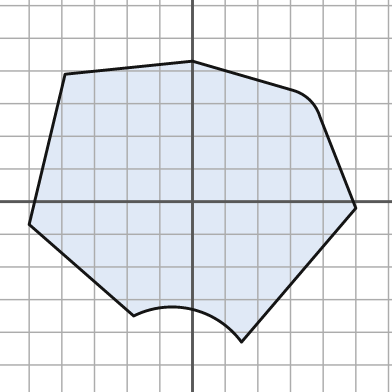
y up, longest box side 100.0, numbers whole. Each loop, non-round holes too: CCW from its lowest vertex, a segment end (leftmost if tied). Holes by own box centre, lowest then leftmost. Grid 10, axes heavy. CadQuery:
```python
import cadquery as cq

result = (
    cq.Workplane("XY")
    .moveTo(15.0, -43.0)
    .lineTo(50.0, -2.0)
    .lineTo(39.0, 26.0)
    .threePointArc((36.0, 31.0), (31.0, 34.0))
    .lineTo(0.0, 43.0)
    .lineTo(-39.0, 39.0)
    .lineTo(-50.0, -7.0)
    .lineTo(-18.0, -35.0)
    .threePointArc((0.0, -33.0), (15.0, -43.0))
    .close()
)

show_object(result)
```